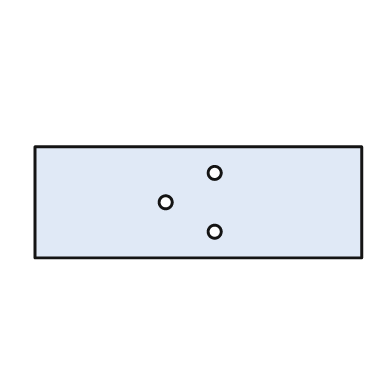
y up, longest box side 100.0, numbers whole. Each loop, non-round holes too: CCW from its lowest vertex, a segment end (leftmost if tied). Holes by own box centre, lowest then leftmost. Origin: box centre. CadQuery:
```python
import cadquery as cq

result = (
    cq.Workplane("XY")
    .moveTo(-50.0, -17.0)
    .lineTo(50.0, -17.0)
    .lineTo(50.0, 17.0)
    .lineTo(-50.0, 17.0)
    .close()
    .moveTo(5.0, -9.0)
    .circle(2.0)
    .moveTo(-10.0, 0.0)
    .circle(2.0)
    .moveTo(5.0, 9.0)
    .circle(2.0)
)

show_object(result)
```